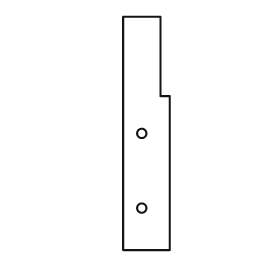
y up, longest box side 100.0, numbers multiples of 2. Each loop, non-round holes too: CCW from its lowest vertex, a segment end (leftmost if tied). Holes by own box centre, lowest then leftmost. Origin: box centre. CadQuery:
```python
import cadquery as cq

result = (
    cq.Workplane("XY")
    .moveTo(-10.0, -50.0)
    .lineTo(10.0, -50.0)
    .lineTo(10.0, 16.0)
    .lineTo(6.0, 16.0)
    .lineTo(6.0, 50.0)
    .lineTo(-10.0, 50.0)
    .close()
    .moveTo(-2.0, -32.0)
    .circle(2.0)
    .moveTo(-2.0, 0.0)
    .circle(2.0)
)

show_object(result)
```